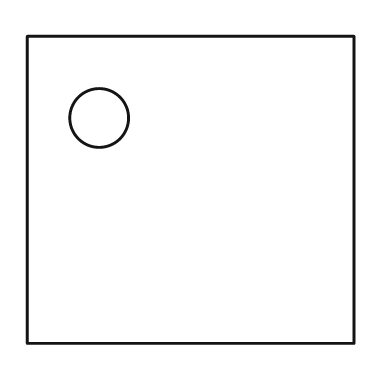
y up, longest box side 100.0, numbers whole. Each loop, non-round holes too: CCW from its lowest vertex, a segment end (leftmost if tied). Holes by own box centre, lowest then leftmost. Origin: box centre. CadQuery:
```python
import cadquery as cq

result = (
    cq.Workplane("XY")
    .moveTo(-50.0, -47.0)
    .lineTo(50.0, -47.0)
    .lineTo(50.0, 47.0)
    .lineTo(-50.0, 47.0)
    .close()
    .moveTo(-28.0, 22.0)
    .circle(9.0)
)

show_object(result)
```